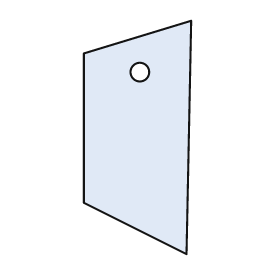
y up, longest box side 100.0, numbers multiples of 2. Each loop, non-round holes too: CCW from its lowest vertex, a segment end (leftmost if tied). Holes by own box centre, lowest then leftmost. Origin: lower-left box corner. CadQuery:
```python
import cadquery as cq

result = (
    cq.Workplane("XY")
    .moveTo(44.0, 0.0)
    .lineTo(46.0, 100.0)
    .lineTo(0.0, 86.0)
    .lineTo(0.0, 22.0)
    .close()
    .moveTo(24.0, 78.0)
    .circle(4.0)
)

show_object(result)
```